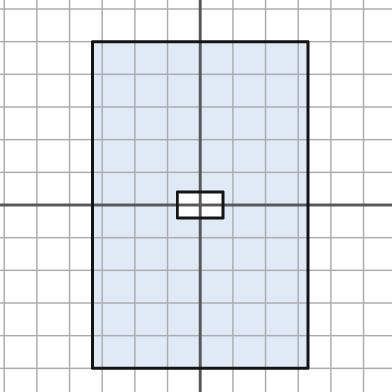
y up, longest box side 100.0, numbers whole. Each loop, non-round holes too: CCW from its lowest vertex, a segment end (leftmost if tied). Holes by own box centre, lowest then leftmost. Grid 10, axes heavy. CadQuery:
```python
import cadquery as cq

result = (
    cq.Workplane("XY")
    .moveTo(-33.0, -50.0)
    .lineTo(33.0, -50.0)
    .lineTo(33.0, 50.0)
    .lineTo(-33.0, 50.0)
    .close()
    .moveTo(-7.0, -4.0)
    .lineTo(7.0, -4.0)
    .lineTo(7.0, 4.0)
    .lineTo(-7.0, 4.0)
    .close()
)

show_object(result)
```